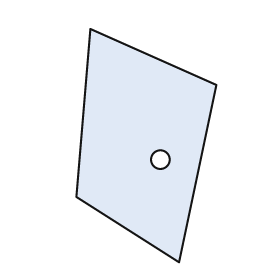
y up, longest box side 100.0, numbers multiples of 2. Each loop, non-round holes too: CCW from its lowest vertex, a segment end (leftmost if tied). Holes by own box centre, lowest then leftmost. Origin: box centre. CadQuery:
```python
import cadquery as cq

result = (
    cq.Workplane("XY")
    .moveTo(14.0, -50.0)
    .lineTo(30.0, 26.0)
    .lineTo(-24.0, 50.0)
    .lineTo(-30.0, -22.0)
    .close()
    .moveTo(6.0, -6.0)
    .circle(4.0)
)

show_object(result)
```